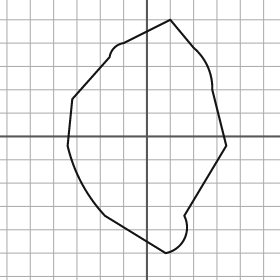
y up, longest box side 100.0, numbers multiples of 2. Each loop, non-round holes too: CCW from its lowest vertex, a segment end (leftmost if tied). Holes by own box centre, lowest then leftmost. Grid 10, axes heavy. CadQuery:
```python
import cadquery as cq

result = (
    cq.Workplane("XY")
    .moveTo(8.0, -50.0)
    .threePointArc((16.0, -44.0), (16.0, -34.0))
    .lineTo(34.0, -4.0)
    .lineTo(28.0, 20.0)
    .threePointArc((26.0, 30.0), (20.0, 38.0))
    .lineTo(10.0, 50.0)
    .lineTo(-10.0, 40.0)
    .threePointArc((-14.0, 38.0), (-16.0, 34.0))
    .lineTo(-32.0, 16.0)
    .lineTo(-34.0, -4.0)
    .threePointArc((-28.0, -20.0), (-18.0, -34.0))
    .close()
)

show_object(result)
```